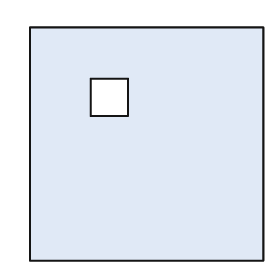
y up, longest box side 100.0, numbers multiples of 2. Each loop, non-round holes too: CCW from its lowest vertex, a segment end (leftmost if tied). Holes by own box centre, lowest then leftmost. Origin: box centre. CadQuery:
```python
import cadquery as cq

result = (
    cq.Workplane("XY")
    .moveTo(-50.0, -50.0)
    .lineTo(50.0, -50.0)
    .lineTo(50.0, 50.0)
    .lineTo(-50.0, 50.0)
    .close()
    .moveTo(-24.0, 12.0)
    .lineTo(-8.0, 12.0)
    .lineTo(-8.0, 28.0)
    .lineTo(-24.0, 28.0)
    .close()
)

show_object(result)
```